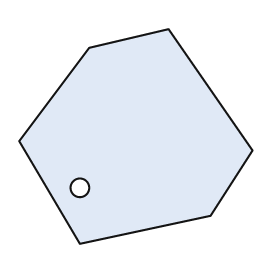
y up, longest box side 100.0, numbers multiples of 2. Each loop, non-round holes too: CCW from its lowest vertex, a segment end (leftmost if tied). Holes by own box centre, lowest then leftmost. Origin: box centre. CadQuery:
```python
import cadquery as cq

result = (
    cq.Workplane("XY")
    .moveTo(-24.0, -46.0)
    .lineTo(32.0, -34.0)
    .lineTo(50.0, -6.0)
    .lineTo(14.0, 46.0)
    .lineTo(-20.0, 38.0)
    .lineTo(-50.0, -2.0)
    .close()
    .moveTo(-24.0, -22.0)
    .circle(4.0)
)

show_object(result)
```